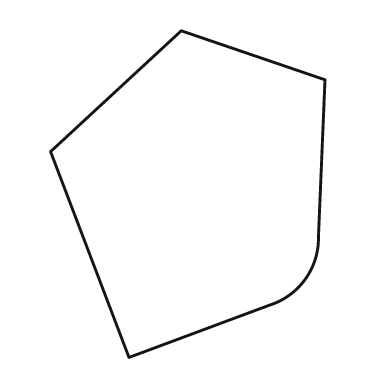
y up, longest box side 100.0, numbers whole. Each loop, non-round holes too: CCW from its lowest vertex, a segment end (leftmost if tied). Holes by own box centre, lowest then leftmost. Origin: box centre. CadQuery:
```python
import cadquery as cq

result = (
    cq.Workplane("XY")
    .moveTo(-18.0, -50.0)
    .lineTo(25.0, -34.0)
    .threePointArc((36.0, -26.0), (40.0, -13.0))
    .lineTo(42.0, 35.0)
    .lineTo(-2.0, 50.0)
    .lineTo(-42.0, 13.0)
    .close()
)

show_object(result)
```